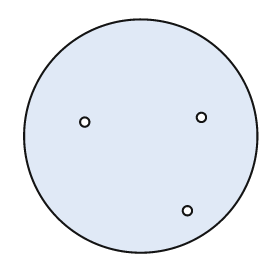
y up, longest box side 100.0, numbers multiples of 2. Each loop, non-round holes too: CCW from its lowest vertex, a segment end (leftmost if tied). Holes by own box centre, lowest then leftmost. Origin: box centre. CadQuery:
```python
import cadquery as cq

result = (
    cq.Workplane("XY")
    .moveTo(0.0, 0.0)
    .circle(50.0)
    .moveTo(20.0, -32.0)
    .circle(2.0)
    .moveTo(-24.0, 6.0)
    .circle(2.0)
    .moveTo(26.0, 8.0)
    .circle(2.0)
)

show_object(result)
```